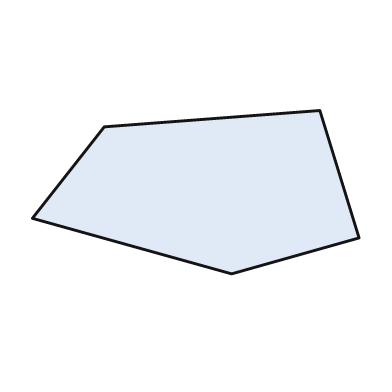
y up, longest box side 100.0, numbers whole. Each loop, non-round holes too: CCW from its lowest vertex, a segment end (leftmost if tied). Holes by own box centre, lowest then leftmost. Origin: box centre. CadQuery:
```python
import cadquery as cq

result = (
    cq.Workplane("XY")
    .moveTo(11.0, -25.0)
    .lineTo(50.0, -14.0)
    .lineTo(38.0, 25.0)
    .lineTo(-28.0, 20.0)
    .lineTo(-50.0, -8.0)
    .close()
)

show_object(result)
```